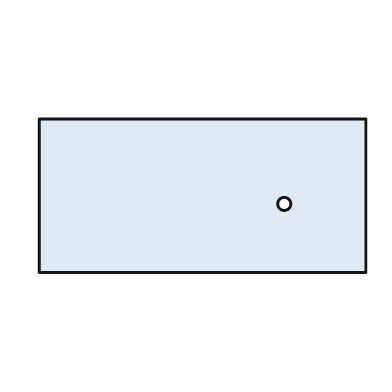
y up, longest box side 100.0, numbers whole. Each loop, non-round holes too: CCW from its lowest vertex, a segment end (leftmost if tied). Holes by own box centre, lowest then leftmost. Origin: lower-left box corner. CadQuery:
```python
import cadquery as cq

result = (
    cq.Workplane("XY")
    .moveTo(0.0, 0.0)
    .lineTo(100.0, 0.0)
    .lineTo(100.0, 47.0)
    .lineTo(0.0, 47.0)
    .close()
    .moveTo(75.0, 21.0)
    .circle(2.0)
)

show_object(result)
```